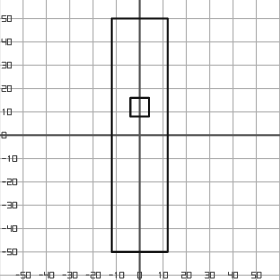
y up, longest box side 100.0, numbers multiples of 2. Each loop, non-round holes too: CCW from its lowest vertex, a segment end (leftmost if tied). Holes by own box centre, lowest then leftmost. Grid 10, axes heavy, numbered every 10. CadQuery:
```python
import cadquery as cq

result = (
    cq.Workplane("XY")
    .moveTo(-12.0, -50.0)
    .lineTo(12.0, -50.0)
    .lineTo(12.0, 50.0)
    .lineTo(-12.0, 50.0)
    .close()
    .moveTo(-4.0, 8.0)
    .lineTo(4.0, 8.0)
    .lineTo(4.0, 16.0)
    .lineTo(-4.0, 16.0)
    .close()
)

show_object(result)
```